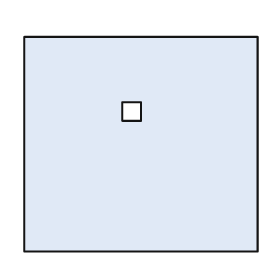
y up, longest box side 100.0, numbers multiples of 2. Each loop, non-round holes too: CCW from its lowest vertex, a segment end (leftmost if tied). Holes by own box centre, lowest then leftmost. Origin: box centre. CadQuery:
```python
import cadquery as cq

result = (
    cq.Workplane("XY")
    .moveTo(-50.0, -46.0)
    .lineTo(50.0, -46.0)
    .lineTo(50.0, 46.0)
    .lineTo(-50.0, 46.0)
    .close()
    .moveTo(-8.0, 10.0)
    .lineTo(0.0, 10.0)
    .lineTo(0.0, 18.0)
    .lineTo(-8.0, 18.0)
    .close()
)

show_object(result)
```